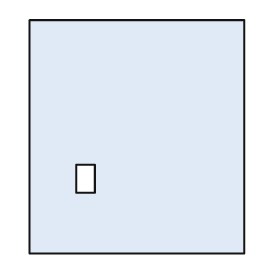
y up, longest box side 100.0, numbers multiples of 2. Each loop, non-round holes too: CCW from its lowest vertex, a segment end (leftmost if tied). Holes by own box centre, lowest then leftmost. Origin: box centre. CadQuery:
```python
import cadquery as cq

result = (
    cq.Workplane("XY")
    .moveTo(-46.0, -50.0)
    .lineTo(46.0, -50.0)
    .lineTo(46.0, 50.0)
    .lineTo(-46.0, 50.0)
    .close()
    .moveTo(-26.0, -24.0)
    .lineTo(-18.0, -24.0)
    .lineTo(-18.0, -12.0)
    .lineTo(-26.0, -12.0)
    .close()
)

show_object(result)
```